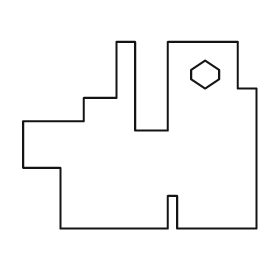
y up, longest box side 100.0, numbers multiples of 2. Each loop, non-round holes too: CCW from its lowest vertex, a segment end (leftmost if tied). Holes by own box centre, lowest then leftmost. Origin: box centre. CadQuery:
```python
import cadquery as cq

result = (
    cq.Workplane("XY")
    .moveTo(-34.0, -40.0)
    .lineTo(12.0, -40.0)
    .lineTo(12.0, -26.0)
    .lineTo(16.0, -26.0)
    .lineTo(16.0, -40.0)
    .lineTo(50.0, -40.0)
    .lineTo(50.0, 20.0)
    .lineTo(42.0, 20.0)
    .lineTo(42.0, 40.0)
    .lineTo(12.0, 40.0)
    .lineTo(12.0, 2.0)
    .lineTo(-2.0, 2.0)
    .lineTo(-2.0, 40.0)
    .lineTo(-10.0, 40.0)
    .lineTo(-10.0, 16.0)
    .lineTo(-24.0, 16.0)
    .lineTo(-24.0, 6.0)
    .lineTo(-50.0, 6.0)
    .lineTo(-50.0, -14.0)
    .lineTo(-34.0, -14.0)
    .close()
    .moveTo(28.0, 20.0)
    .lineTo(34.0, 24.0)
    .lineTo(34.0, 28.0)
    .lineTo(28.0, 32.0)
    .lineTo(22.0, 28.0)
    .lineTo(22.0, 24.0)
    .close()
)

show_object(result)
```